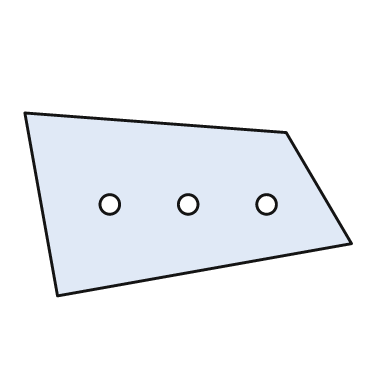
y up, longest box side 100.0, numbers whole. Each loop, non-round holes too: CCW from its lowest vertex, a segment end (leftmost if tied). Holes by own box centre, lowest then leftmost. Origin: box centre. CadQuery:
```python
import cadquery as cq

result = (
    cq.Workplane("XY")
    .moveTo(-40.0, -28.0)
    .lineTo(50.0, -12.0)
    .lineTo(30.0, 22.0)
    .lineTo(-50.0, 28.0)
    .close()
    .moveTo(-24.0, 0.0)
    .circle(3.0)
    .moveTo(0.0, 0.0)
    .circle(3.0)
    .moveTo(24.0, 0.0)
    .circle(3.0)
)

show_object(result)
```